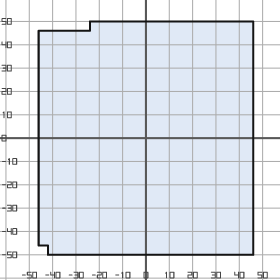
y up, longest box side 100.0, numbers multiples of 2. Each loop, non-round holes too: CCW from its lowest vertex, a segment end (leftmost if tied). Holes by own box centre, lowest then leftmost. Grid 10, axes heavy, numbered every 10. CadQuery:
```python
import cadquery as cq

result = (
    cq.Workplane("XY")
    .moveTo(-42.0, -50.0)
    .lineTo(46.0, -50.0)
    .lineTo(46.0, 50.0)
    .lineTo(-24.0, 50.0)
    .lineTo(-24.0, 46.0)
    .lineTo(-46.0, 46.0)
    .lineTo(-46.0, -46.0)
    .lineTo(-42.0, -46.0)
    .close()
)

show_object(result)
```